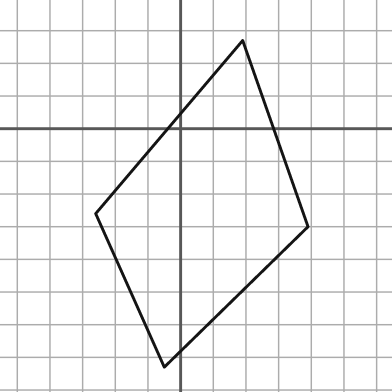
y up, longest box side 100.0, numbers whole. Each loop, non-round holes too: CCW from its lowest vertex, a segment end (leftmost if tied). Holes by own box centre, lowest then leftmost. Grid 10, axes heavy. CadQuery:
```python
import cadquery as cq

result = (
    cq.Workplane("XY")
    .moveTo(-5.0, -73.0)
    .lineTo(39.0, -30.0)
    .lineTo(19.0, 27.0)
    .lineTo(-26.0, -26.0)
    .close()
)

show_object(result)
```